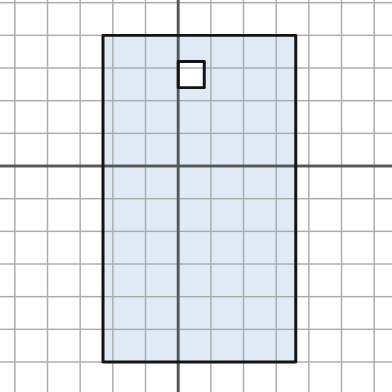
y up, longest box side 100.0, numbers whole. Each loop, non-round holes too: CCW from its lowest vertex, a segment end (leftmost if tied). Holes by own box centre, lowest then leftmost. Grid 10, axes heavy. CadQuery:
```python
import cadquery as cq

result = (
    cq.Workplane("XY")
    .moveTo(-23.0, -60.0)
    .lineTo(36.0, -60.0)
    .lineTo(36.0, 40.0)
    .lineTo(-23.0, 40.0)
    .close()
    .moveTo(0.0, 24.0)
    .lineTo(8.0, 24.0)
    .lineTo(8.0, 32.0)
    .lineTo(0.0, 32.0)
    .close()
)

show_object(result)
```